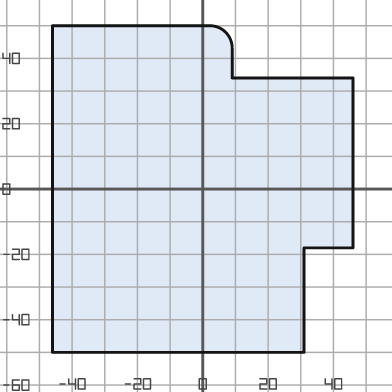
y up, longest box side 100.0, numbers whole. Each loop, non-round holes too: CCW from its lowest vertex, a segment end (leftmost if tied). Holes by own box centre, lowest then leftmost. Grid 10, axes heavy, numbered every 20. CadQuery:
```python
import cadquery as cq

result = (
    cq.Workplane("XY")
    .moveTo(-46.0, -50.0)
    .lineTo(31.0, -50.0)
    .lineTo(31.0, -18.0)
    .lineTo(46.0, -18.0)
    .lineTo(46.0, 34.0)
    .lineTo(9.0, 34.0)
    .lineTo(9.0, 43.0)
    .threePointArc((7.0, 48.0), (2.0, 50.0))
    .lineTo(-46.0, 50.0)
    .close()
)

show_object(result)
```